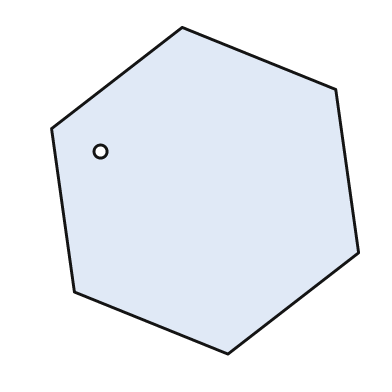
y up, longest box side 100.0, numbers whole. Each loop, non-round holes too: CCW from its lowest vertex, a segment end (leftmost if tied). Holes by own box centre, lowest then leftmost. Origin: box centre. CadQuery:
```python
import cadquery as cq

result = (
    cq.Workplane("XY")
    .moveTo(7.0, -50.0)
    .lineTo(47.0, -19.0)
    .lineTo(40.0, 31.0)
    .lineTo(-7.0, 50.0)
    .lineTo(-47.0, 19.0)
    .lineTo(-40.0, -31.0)
    .close()
    .moveTo(-32.0, 12.0)
    .circle(2.0)
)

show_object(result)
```